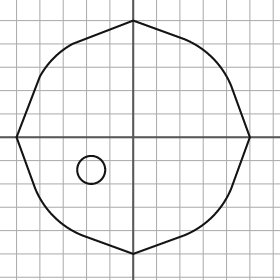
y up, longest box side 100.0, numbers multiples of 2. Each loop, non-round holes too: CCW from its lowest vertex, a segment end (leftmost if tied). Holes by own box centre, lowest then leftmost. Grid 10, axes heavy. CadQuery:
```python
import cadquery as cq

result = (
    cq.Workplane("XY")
    .moveTo(0.0, -50.0)
    .lineTo(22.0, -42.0)
    .threePointArc((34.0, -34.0), (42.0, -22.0))
    .lineTo(50.0, 0.0)
    .lineTo(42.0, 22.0)
    .threePointArc((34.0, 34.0), (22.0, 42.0))
    .lineTo(0.0, 50.0)
    .lineTo(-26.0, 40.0)
    .threePointArc((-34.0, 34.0), (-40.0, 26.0))
    .lineTo(-50.0, 0.0)
    .lineTo(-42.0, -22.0)
    .threePointArc((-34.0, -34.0), (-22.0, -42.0))
    .close()
    .moveTo(-18.0, -14.0)
    .circle(6.0)
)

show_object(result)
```